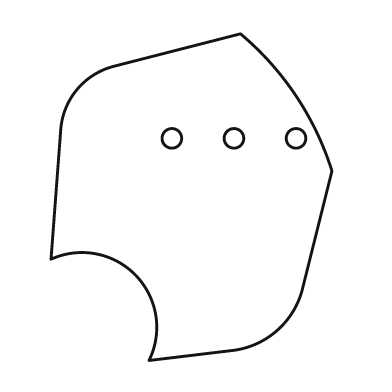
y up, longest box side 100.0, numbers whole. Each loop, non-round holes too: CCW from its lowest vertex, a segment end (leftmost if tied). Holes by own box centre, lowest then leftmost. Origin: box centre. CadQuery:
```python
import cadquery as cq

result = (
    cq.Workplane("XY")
    .moveTo(-13.0, -50.0)
    .lineTo(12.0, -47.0)
    .threePointArc((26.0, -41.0), (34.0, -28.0))
    .lineTo(43.0, 8.0)
    .threePointArc((32.0, 31.0), (15.0, 50.0))
    .lineTo(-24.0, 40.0)
    .threePointArc((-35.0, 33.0), (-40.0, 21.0))
    .lineTo(-43.0, -19.0)
    .threePointArc((-17.0, -24.0), (-13.0, -50.0))
    .close()
    .moveTo(-6.0, 18.0)
    .circle(3.0)
    .moveTo(13.0, 18.0)
    .circle(3.0)
    .moveTo(32.0, 18.0)
    .circle(3.0)
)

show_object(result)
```